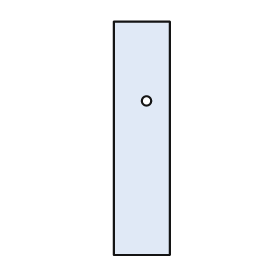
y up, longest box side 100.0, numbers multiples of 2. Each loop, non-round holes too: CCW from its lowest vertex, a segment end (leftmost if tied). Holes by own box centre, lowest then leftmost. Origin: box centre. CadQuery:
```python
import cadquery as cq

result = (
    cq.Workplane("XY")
    .moveTo(-12.0, -50.0)
    .lineTo(12.0, -50.0)
    .lineTo(12.0, 50.0)
    .lineTo(-12.0, 50.0)
    .close()
    .moveTo(2.0, 16.0)
    .circle(2.0)
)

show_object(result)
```